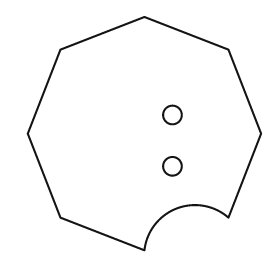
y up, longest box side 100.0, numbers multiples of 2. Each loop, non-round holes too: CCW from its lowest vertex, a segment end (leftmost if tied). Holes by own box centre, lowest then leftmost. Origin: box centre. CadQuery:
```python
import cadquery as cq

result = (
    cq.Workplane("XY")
    .moveTo(0.0, -50.0)
    .threePointArc((14.0, -32.0), (36.0, -36.0))
    .lineTo(50.0, 0.0)
    .lineTo(36.0, 36.0)
    .lineTo(0.0, 50.0)
    .lineTo(-36.0, 36.0)
    .lineTo(-50.0, 0.0)
    .lineTo(-36.0, -36.0)
    .close()
    .moveTo(12.0, -14.0)
    .circle(4.0)
    .moveTo(12.0, 8.0)
    .circle(4.0)
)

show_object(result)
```